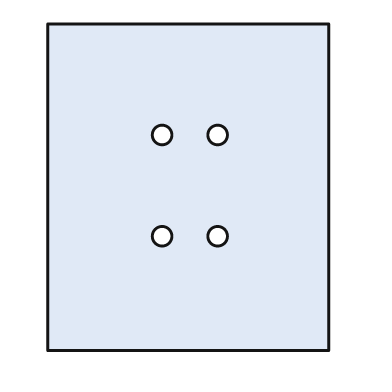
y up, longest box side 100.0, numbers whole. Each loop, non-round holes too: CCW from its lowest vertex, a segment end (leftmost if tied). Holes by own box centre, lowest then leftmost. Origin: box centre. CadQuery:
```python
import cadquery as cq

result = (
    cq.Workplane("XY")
    .moveTo(-43.0, -50.0)
    .lineTo(43.0, -50.0)
    .lineTo(43.0, 50.0)
    .lineTo(-43.0, 50.0)
    .close()
    .moveTo(-8.0, -15.0)
    .circle(3.0)
    .moveTo(9.0, -15.0)
    .circle(3.0)
    .moveTo(-8.0, 16.0)
    .circle(3.0)
    .moveTo(9.0, 16.0)
    .circle(3.0)
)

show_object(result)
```